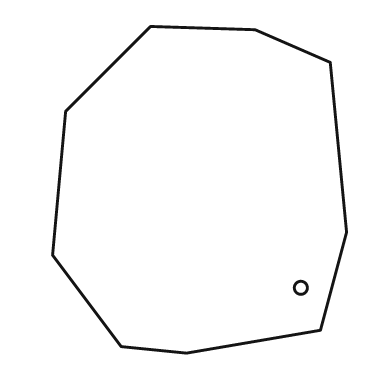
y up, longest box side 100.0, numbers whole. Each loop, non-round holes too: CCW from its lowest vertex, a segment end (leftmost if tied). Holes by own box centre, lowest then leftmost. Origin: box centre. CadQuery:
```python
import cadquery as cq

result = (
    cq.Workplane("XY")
    .moveTo(-4.0, -50.0)
    .lineTo(37.0, -43.0)
    .lineTo(45.0, -13.0)
    .lineTo(40.0, 39.0)
    .lineTo(17.0, 49.0)
    .lineTo(-15.0, 50.0)
    .lineTo(-41.0, 24.0)
    .lineTo(-45.0, -20.0)
    .lineTo(-24.0, -48.0)
    .close()
    .moveTo(31.0, -30.0)
    .circle(2.0)
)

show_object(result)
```